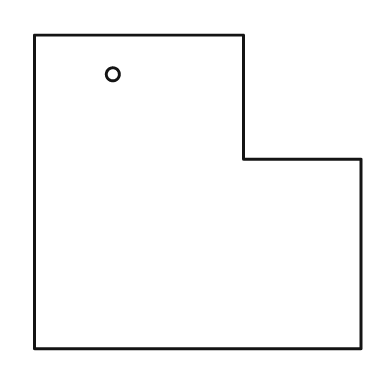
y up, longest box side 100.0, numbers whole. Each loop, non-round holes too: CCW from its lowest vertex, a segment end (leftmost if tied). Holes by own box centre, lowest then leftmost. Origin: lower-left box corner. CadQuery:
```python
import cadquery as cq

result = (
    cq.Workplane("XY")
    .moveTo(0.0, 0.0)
    .lineTo(100.0, 0.0)
    .lineTo(100.0, 58.0)
    .lineTo(64.0, 58.0)
    .lineTo(64.0, 96.0)
    .lineTo(0.0, 96.0)
    .close()
    .moveTo(24.0, 84.0)
    .circle(2.0)
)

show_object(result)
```